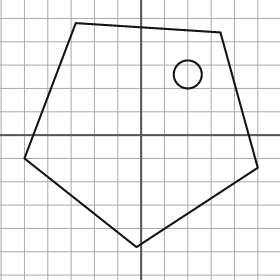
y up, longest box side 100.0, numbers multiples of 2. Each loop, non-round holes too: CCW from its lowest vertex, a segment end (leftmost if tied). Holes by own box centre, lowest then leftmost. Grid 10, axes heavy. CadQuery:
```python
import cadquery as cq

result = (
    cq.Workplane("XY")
    .moveTo(-2.0, -48.0)
    .lineTo(50.0, -14.0)
    .lineTo(34.0, 44.0)
    .lineTo(-28.0, 48.0)
    .lineTo(-50.0, -10.0)
    .close()
    .moveTo(20.0, 26.0)
    .circle(6.0)
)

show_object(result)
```